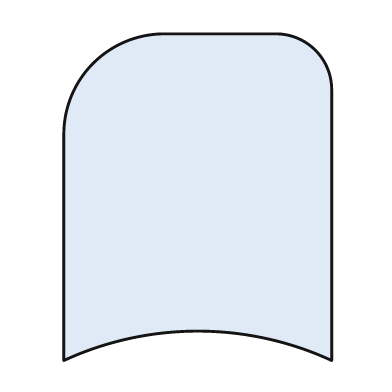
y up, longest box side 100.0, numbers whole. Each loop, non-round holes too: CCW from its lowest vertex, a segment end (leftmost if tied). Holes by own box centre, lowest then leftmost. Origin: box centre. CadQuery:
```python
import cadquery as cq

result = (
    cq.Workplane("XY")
    .moveTo(-41.0, -50.0)
    .threePointArc((0.0, -41.0), (41.0, -50.0))
    .lineTo(41.0, 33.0)
    .threePointArc((36.0, 45.0), (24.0, 50.0))
    .lineTo(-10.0, 50.0)
    .threePointArc((-32.0, 41.0), (-41.0, 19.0))
    .close()
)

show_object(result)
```